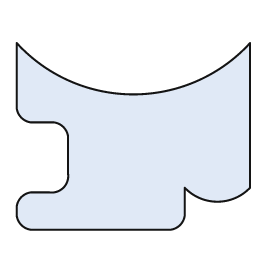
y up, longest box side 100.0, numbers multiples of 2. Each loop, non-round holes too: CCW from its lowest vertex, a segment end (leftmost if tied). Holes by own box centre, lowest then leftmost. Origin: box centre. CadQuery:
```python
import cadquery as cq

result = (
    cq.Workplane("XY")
    .moveTo(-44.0, -40.0)
    .lineTo(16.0, -40.0)
    .threePointArc((20.0, -38.0), (22.0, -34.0))
    .lineTo(22.0, -22.0)
    .threePointArc((36.0, -28.0), (50.0, -22.0))
    .lineTo(50.0, 40.0)
    .threePointArc((0.0, 18.0), (-50.0, 40.0))
    .lineTo(-50.0, 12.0)
    .threePointArc((-48.0, 8.0), (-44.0, 6.0))
    .lineTo(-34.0, 6.0)
    .threePointArc((-30.0, 4.0), (-28.0, 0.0))
    .lineTo(-28.0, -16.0)
    .threePointArc((-30.0, -22.0), (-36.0, -24.0))
    .lineTo(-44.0, -24.0)
    .threePointArc((-48.0, -26.0), (-50.0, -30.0))
    .lineTo(-50.0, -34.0)
    .threePointArc((-48.0, -38.0), (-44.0, -40.0))
    .close()
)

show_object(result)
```